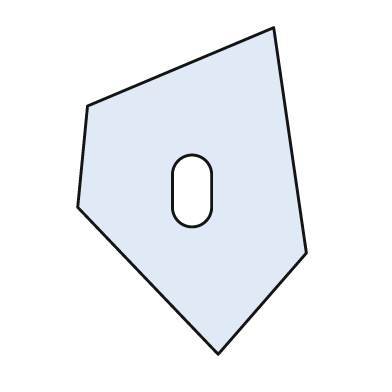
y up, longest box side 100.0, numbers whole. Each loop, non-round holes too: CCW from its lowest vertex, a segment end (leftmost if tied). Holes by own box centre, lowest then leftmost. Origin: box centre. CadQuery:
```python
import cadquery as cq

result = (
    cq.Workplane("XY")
    .moveTo(8.0, -50.0)
    .lineTo(35.0, -19.0)
    .lineTo(25.0, 50.0)
    .lineTo(-32.0, 26.0)
    .lineTo(-35.0, -5.0)
    .close()
    .moveTo(-6.0, -5.0)
    .threePointArc((0.0, -11.0), (6.0, -5.0))
    .lineTo(6.0, 5.0)
    .threePointArc((0.0, 11.0), (-6.0, 5.0))
    .close()
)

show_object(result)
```